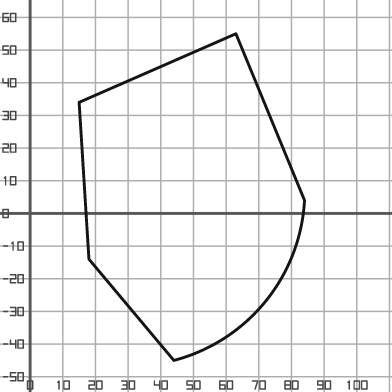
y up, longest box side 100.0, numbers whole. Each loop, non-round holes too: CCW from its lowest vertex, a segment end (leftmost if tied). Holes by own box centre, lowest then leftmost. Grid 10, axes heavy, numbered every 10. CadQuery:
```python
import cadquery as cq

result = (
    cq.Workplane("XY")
    .moveTo(44.0, -45.0)
    .threePointArc((72.0, -27.0), (84.0, 4.0))
    .lineTo(63.0, 55.0)
    .lineTo(15.0, 34.0)
    .lineTo(18.0, -14.0)
    .close()
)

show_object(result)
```